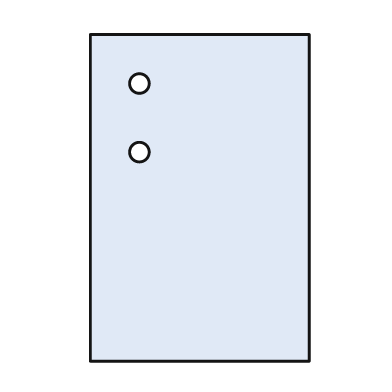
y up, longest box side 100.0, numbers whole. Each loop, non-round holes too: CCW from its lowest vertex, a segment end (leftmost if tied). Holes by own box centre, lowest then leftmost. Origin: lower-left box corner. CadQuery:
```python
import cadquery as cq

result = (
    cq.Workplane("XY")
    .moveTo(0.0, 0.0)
    .lineTo(67.0, 0.0)
    .lineTo(67.0, 100.0)
    .lineTo(0.0, 100.0)
    .close()
    .moveTo(15.0, 64.0)
    .circle(3.0)
    .moveTo(15.0, 85.0)
    .circle(3.0)
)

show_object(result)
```